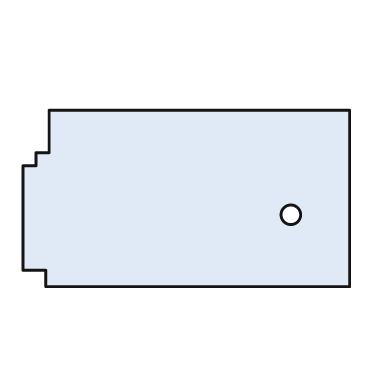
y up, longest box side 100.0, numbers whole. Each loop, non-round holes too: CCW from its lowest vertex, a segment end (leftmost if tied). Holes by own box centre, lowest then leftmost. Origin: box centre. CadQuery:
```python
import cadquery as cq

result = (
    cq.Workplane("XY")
    .moveTo(-43.0, -27.0)
    .lineTo(50.0, -27.0)
    .lineTo(50.0, 27.0)
    .lineTo(-42.0, 27.0)
    .lineTo(-42.0, 14.0)
    .lineTo(-46.0, 14.0)
    .lineTo(-46.0, 10.0)
    .lineTo(-50.0, 10.0)
    .lineTo(-50.0, -22.0)
    .lineTo(-43.0, -22.0)
    .close()
    .moveTo(32.0, -5.0)
    .circle(3.0)
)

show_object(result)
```